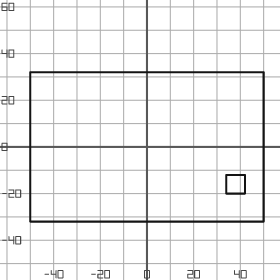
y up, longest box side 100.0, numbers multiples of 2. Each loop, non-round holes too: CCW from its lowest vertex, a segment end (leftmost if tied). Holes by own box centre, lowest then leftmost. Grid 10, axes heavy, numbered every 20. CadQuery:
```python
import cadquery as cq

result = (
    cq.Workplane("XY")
    .moveTo(-50.0, -32.0)
    .lineTo(50.0, -32.0)
    .lineTo(50.0, 32.0)
    .lineTo(-50.0, 32.0)
    .close()
    .moveTo(34.0, -20.0)
    .lineTo(42.0, -20.0)
    .lineTo(42.0, -12.0)
    .lineTo(34.0, -12.0)
    .close()
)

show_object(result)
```